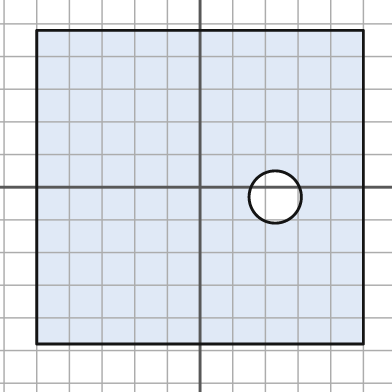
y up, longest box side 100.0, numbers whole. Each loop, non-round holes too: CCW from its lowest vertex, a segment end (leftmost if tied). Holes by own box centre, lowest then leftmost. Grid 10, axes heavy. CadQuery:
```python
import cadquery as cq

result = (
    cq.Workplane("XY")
    .moveTo(-50.0, -48.0)
    .lineTo(50.0, -48.0)
    .lineTo(50.0, 48.0)
    .lineTo(-50.0, 48.0)
    .close()
    .moveTo(23.0, -3.0)
    .circle(8.0)
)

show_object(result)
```